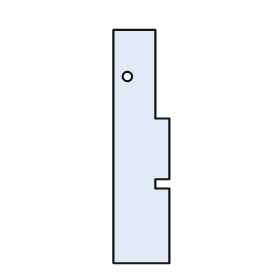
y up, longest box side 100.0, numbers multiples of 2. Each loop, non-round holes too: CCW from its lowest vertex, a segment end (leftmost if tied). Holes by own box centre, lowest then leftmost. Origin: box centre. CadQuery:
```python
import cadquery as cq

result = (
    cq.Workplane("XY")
    .moveTo(-12.0, -50.0)
    .lineTo(12.0, -50.0)
    .lineTo(12.0, -18.0)
    .lineTo(6.0, -18.0)
    .lineTo(6.0, -14.0)
    .lineTo(12.0, -14.0)
    .lineTo(12.0, 12.0)
    .lineTo(6.0, 12.0)
    .lineTo(6.0, 50.0)
    .lineTo(-12.0, 50.0)
    .close()
    .moveTo(-6.0, 30.0)
    .circle(2.0)
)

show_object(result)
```